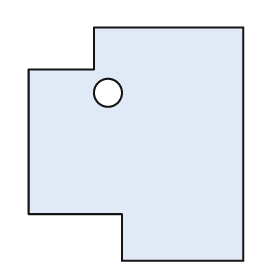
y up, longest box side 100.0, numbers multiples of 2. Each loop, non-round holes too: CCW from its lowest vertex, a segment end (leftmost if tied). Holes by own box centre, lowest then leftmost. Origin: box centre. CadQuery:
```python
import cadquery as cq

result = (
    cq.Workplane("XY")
    .moveTo(-6.0, -50.0)
    .lineTo(46.0, -50.0)
    .lineTo(46.0, 50.0)
    .lineTo(-18.0, 50.0)
    .lineTo(-18.0, 32.0)
    .lineTo(-46.0, 32.0)
    .lineTo(-46.0, -30.0)
    .lineTo(-6.0, -30.0)
    .close()
    .moveTo(-12.0, 22.0)
    .circle(6.0)
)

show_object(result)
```